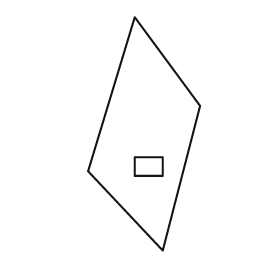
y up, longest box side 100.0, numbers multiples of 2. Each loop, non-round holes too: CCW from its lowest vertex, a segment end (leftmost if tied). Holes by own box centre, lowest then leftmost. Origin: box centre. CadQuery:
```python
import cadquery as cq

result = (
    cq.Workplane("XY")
    .moveTo(8.0, -50.0)
    .lineTo(24.0, 12.0)
    .lineTo(-4.0, 50.0)
    .lineTo(-24.0, -16.0)
    .close()
    .moveTo(-4.0, -18.0)
    .lineTo(8.0, -18.0)
    .lineTo(8.0, -10.0)
    .lineTo(-4.0, -10.0)
    .close()
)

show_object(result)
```